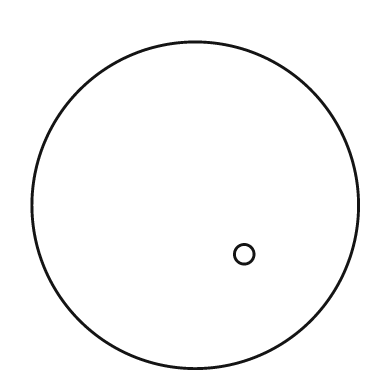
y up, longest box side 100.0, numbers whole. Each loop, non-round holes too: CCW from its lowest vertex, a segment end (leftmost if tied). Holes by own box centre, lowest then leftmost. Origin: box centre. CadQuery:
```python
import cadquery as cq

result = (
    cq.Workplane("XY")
    .moveTo(0.0, 0.0)
    .circle(50.0)
    .moveTo(15.0, -15.0)
    .circle(3.0)
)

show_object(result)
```